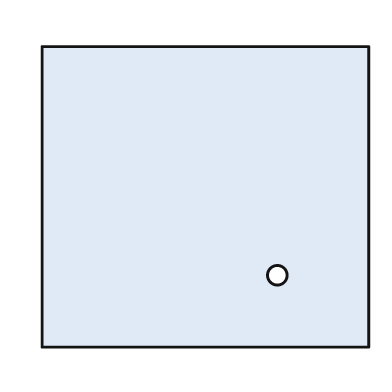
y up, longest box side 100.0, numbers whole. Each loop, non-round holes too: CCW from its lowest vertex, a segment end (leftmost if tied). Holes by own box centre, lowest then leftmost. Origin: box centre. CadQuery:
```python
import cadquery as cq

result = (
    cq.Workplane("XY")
    .moveTo(-50.0, -46.0)
    .lineTo(50.0, -46.0)
    .lineTo(50.0, 46.0)
    .lineTo(-50.0, 46.0)
    .close()
    .moveTo(22.0, -24.0)
    .circle(3.0)
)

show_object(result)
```